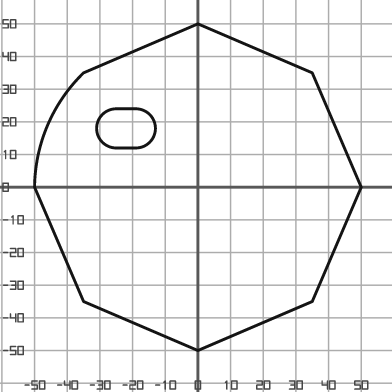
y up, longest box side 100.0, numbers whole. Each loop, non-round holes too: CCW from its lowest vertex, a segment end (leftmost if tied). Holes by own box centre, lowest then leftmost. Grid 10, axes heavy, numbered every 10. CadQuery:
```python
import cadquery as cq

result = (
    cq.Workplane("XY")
    .moveTo(0.0, -50.0)
    .lineTo(35.0, -35.0)
    .lineTo(50.0, 0.0)
    .lineTo(35.0, 35.0)
    .lineTo(0.0, 50.0)
    .lineTo(-35.0, 35.0)
    .threePointArc((-46.0, 19.0), (-50.0, 0.0))
    .lineTo(-35.0, -35.0)
    .close()
    .moveTo(-25.0, 12.0)
    .lineTo(-19.0, 12.0)
    .threePointArc((-13.0, 18.0), (-19.0, 24.0))
    .lineTo(-25.0, 24.0)
    .threePointArc((-31.0, 18.0), (-25.0, 12.0))
    .close()
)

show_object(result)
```